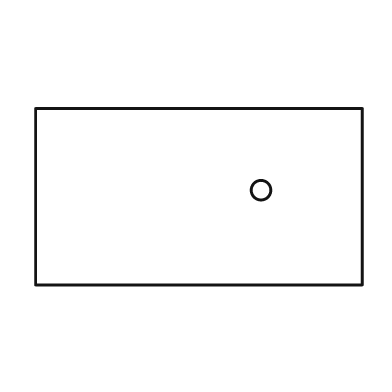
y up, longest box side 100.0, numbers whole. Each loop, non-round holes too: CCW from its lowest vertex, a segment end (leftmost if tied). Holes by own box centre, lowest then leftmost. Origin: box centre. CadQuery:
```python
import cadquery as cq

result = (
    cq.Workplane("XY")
    .moveTo(-50.0, -27.0)
    .lineTo(50.0, -27.0)
    .lineTo(50.0, 27.0)
    .lineTo(-50.0, 27.0)
    .close()
    .moveTo(19.0, 2.0)
    .circle(3.0)
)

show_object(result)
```